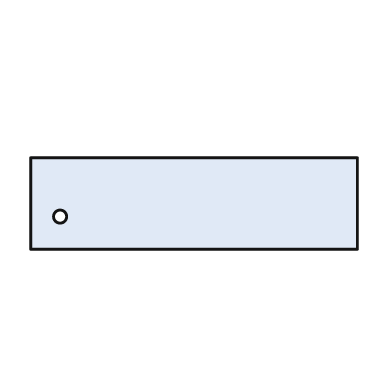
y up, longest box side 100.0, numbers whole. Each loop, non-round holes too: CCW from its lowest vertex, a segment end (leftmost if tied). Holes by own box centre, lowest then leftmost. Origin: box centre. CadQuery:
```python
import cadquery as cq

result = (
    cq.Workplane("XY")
    .moveTo(-50.0, -14.0)
    .lineTo(50.0, -14.0)
    .lineTo(50.0, 14.0)
    .lineTo(-50.0, 14.0)
    .close()
    .moveTo(-41.0, -4.0)
    .circle(2.0)
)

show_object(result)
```